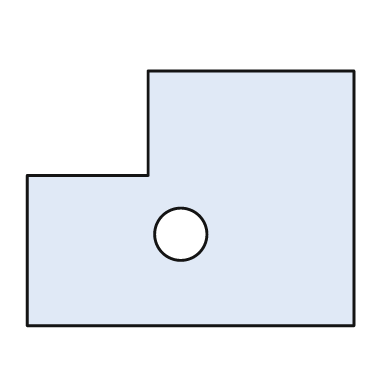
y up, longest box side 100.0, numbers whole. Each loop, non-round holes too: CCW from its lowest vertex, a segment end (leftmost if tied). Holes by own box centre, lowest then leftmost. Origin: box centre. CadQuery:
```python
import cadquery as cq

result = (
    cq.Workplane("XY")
    .moveTo(-50.0, -39.0)
    .lineTo(50.0, -39.0)
    .lineTo(50.0, 39.0)
    .lineTo(-13.0, 39.0)
    .lineTo(-13.0, 7.0)
    .lineTo(-50.0, 7.0)
    .close()
    .moveTo(-3.0, -11.0)
    .circle(8.0)
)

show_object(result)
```